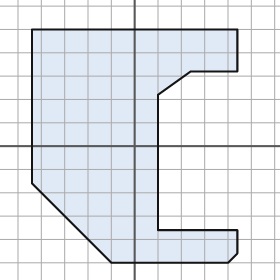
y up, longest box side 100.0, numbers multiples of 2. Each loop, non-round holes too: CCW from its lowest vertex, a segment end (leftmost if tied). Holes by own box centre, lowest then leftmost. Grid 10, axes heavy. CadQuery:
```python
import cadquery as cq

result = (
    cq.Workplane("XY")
    .moveTo(-10.0, -50.0)
    .lineTo(40.0, -50.0)
    .lineTo(44.0, -46.0)
    .lineTo(44.0, -36.0)
    .lineTo(10.0, -36.0)
    .lineTo(10.0, 22.0)
    .lineTo(24.0, 32.0)
    .lineTo(44.0, 32.0)
    .lineTo(44.0, 50.0)
    .lineTo(-44.0, 50.0)
    .lineTo(-44.0, -16.0)
    .close()
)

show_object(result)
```